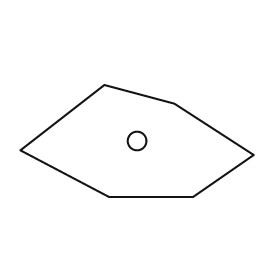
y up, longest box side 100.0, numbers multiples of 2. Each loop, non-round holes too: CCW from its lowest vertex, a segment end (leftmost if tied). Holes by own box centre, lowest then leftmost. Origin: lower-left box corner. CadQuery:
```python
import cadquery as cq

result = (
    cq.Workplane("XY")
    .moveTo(38.0, 0.0)
    .lineTo(74.0, 0.0)
    .lineTo(100.0, 18.0)
    .lineTo(66.0, 40.0)
    .lineTo(36.0, 48.0)
    .lineTo(0.0, 20.0)
    .close()
    .moveTo(50.0, 24.0)
    .circle(4.0)
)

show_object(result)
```